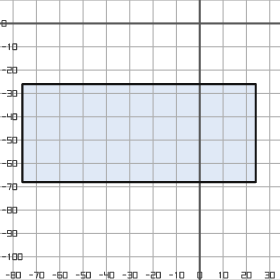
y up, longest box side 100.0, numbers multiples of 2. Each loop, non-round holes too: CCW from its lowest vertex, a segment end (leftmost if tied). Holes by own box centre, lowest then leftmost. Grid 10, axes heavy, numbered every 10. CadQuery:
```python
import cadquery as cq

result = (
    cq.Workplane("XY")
    .moveTo(-76.0, -68.0)
    .lineTo(24.0, -68.0)
    .lineTo(24.0, -26.0)
    .lineTo(-76.0, -26.0)
    .close()
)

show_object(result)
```